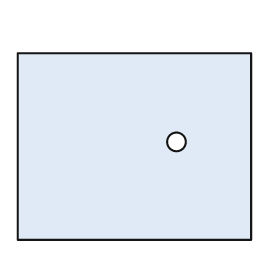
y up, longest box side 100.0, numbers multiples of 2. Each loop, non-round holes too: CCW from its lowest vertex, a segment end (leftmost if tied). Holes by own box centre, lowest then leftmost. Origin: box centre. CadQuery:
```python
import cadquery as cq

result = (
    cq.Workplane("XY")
    .moveTo(-50.0, -40.0)
    .lineTo(50.0, -40.0)
    .lineTo(50.0, 40.0)
    .lineTo(-50.0, 40.0)
    .close()
    .moveTo(18.0, 2.0)
    .circle(4.0)
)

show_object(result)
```